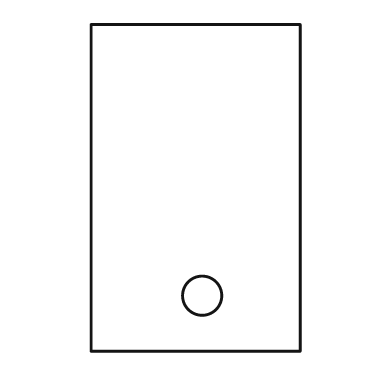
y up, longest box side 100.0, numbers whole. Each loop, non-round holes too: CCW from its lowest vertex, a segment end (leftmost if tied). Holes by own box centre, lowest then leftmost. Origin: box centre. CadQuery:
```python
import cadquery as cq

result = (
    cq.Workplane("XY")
    .moveTo(-32.0, -50.0)
    .lineTo(32.0, -50.0)
    .lineTo(32.0, 50.0)
    .lineTo(-32.0, 50.0)
    .close()
    .moveTo(2.0, -33.0)
    .circle(6.0)
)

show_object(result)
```